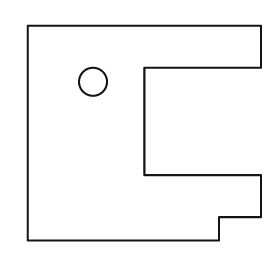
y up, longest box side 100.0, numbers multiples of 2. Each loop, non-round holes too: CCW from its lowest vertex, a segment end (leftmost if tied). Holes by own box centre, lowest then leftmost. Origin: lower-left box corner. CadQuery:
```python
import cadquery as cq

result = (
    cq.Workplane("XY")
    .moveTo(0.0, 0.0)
    .lineTo(82.0, 0.0)
    .lineTo(82.0, 10.0)
    .lineTo(100.0, 10.0)
    .lineTo(100.0, 28.0)
    .lineTo(50.0, 28.0)
    .lineTo(50.0, 74.0)
    .lineTo(100.0, 74.0)
    .lineTo(100.0, 92.0)
    .lineTo(0.0, 92.0)
    .close()
    .moveTo(28.0, 68.0)
    .circle(6.0)
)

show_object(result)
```